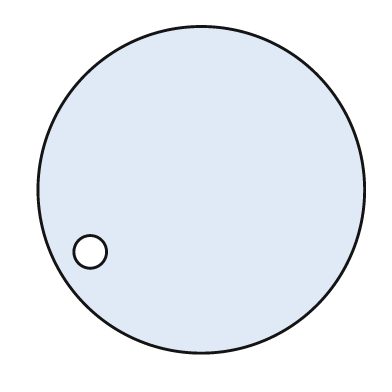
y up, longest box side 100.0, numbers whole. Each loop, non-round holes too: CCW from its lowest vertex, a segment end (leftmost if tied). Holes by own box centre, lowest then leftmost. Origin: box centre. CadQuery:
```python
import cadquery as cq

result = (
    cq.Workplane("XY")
    .moveTo(0.0, 0.0)
    .circle(50.0)
    .moveTo(-34.0, -19.0)
    .circle(5.0)
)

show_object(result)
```